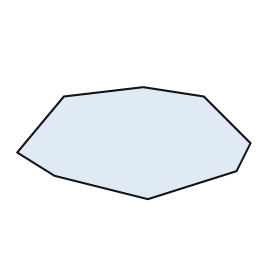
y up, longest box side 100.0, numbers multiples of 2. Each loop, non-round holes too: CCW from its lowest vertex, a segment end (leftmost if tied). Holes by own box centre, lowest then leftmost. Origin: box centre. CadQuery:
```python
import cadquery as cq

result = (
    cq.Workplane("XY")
    .moveTo(6.0, -24.0)
    .lineTo(44.0, -12.0)
    .lineTo(50.0, 0.0)
    .lineTo(30.0, 20.0)
    .lineTo(4.0, 24.0)
    .lineTo(-30.0, 20.0)
    .lineTo(-50.0, -4.0)
    .lineTo(-34.0, -14.0)
    .close()
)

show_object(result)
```